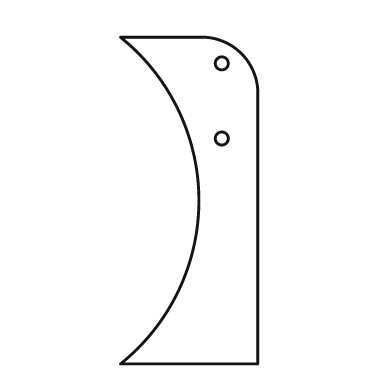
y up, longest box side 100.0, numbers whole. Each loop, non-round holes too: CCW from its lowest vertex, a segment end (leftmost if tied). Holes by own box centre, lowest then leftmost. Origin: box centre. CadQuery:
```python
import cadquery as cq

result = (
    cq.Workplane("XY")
    .moveTo(-21.0, -50.0)
    .lineTo(21.0, -50.0)
    .lineTo(21.0, 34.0)
    .threePointArc((16.0, 45.0), (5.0, 50.0))
    .lineTo(-21.0, 50.0)
    .threePointArc((3.0, 0.0), (-21.0, -50.0))
    .close()
    .moveTo(10.0, 19.0)
    .circle(2.0)
    .moveTo(10.0, 42.0)
    .circle(2.0)
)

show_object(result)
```